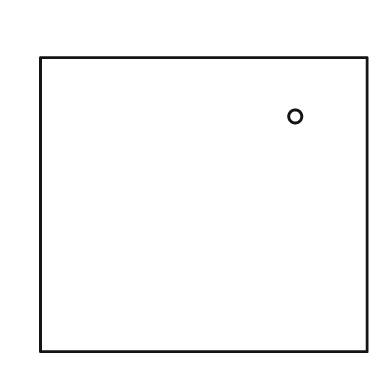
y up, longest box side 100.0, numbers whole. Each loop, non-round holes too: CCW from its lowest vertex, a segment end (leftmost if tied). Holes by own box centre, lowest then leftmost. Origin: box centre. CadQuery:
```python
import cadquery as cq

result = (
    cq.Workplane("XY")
    .moveTo(-50.0, -45.0)
    .lineTo(50.0, -45.0)
    .lineTo(50.0, 45.0)
    .lineTo(-50.0, 45.0)
    .close()
    .moveTo(28.0, 27.0)
    .circle(2.0)
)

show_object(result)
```